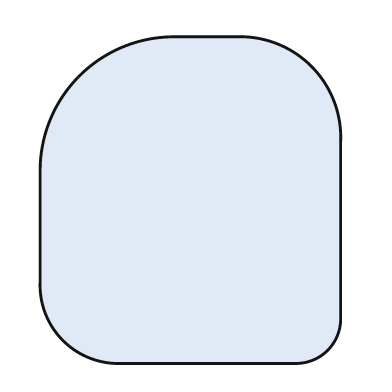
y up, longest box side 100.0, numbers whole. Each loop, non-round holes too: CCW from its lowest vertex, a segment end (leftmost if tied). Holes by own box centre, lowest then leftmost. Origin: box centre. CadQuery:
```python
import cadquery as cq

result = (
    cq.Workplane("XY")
    .moveTo(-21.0, -50.0)
    .lineTo(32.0, -50.0)
    .threePointArc((42.0, -46.0), (46.0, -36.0))
    .lineTo(46.0, 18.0)
    .threePointArc((37.0, 41.0), (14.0, 50.0))
    .lineTo(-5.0, 50.0)
    .threePointArc((-34.0, 38.0), (-46.0, 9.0))
    .lineTo(-46.0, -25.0)
    .threePointArc((-39.0, -43.0), (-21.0, -50.0))
    .close()
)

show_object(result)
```